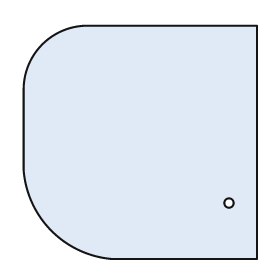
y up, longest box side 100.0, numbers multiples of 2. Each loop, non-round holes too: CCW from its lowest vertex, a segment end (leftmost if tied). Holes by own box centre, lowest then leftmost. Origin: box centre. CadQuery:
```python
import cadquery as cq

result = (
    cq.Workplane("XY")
    .moveTo(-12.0, -50.0)
    .lineTo(50.0, -50.0)
    .lineTo(50.0, 50.0)
    .lineTo(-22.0, 50.0)
    .threePointArc((-42.0, 42.0), (-50.0, 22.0))
    .lineTo(-50.0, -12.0)
    .threePointArc((-38.0, -38.0), (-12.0, -50.0))
    .close()
    .moveTo(38.0, -26.0)
    .circle(2.0)
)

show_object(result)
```